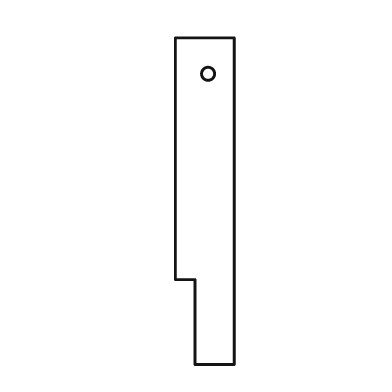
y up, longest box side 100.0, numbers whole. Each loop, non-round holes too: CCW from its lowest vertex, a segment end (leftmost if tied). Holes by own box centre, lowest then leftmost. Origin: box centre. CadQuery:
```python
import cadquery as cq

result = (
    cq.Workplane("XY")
    .moveTo(-3.0, -50.0)
    .lineTo(9.0, -50.0)
    .lineTo(9.0, 50.0)
    .lineTo(-9.0, 50.0)
    .lineTo(-9.0, -24.0)
    .lineTo(-3.0, -24.0)
    .close()
    .moveTo(1.0, 39.0)
    .circle(2.0)
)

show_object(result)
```